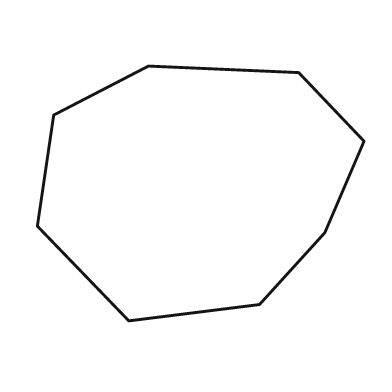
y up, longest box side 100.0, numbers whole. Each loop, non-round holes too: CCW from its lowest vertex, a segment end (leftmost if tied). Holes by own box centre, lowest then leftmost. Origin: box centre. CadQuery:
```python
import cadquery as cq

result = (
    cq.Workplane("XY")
    .moveTo(-22.0, -39.0)
    .lineTo(18.0, -34.0)
    .lineTo(38.0, -12.0)
    .lineTo(50.0, 16.0)
    .lineTo(30.0, 37.0)
    .lineTo(-16.0, 39.0)
    .lineTo(-45.0, 24.0)
    .lineTo(-50.0, -10.0)
    .close()
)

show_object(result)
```